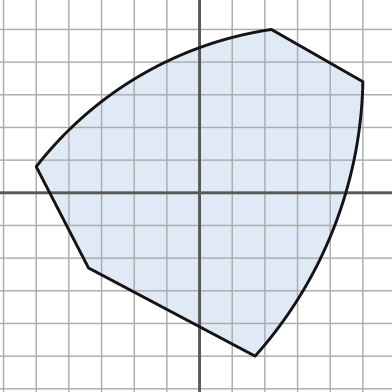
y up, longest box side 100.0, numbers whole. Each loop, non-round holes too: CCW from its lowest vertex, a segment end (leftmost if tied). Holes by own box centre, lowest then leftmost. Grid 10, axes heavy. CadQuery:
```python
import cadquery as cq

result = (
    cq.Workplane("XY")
    .moveTo(17.0, -50.0)
    .threePointArc((41.0, -11.0), (50.0, 34.0))
    .lineTo(22.0, 50.0)
    .threePointArc((-18.0, 36.0), (-50.0, 8.0))
    .lineTo(-34.0, -23.0)
    .close()
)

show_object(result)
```